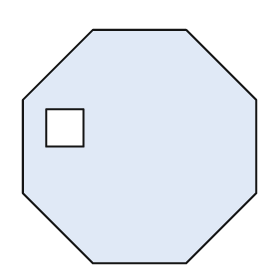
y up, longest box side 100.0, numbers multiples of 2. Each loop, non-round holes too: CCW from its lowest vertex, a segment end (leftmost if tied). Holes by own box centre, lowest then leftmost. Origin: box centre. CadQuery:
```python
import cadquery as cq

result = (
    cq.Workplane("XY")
    .moveTo(-20.0, -50.0)
    .lineTo(20.0, -50.0)
    .lineTo(50.0, -20.0)
    .lineTo(50.0, 20.0)
    .lineTo(20.0, 50.0)
    .lineTo(-20.0, 50.0)
    .lineTo(-50.0, 20.0)
    .lineTo(-50.0, -20.0)
    .close()
    .moveTo(-40.0, 0.0)
    .lineTo(-24.0, 0.0)
    .lineTo(-24.0, 16.0)
    .lineTo(-40.0, 16.0)
    .close()
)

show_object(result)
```